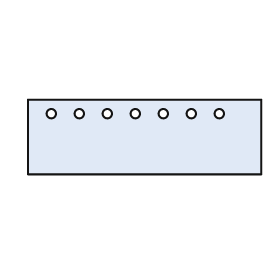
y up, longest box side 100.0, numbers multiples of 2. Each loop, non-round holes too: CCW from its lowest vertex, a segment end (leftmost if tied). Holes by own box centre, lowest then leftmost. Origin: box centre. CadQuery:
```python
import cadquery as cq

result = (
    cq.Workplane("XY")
    .moveTo(-50.0, -16.0)
    .lineTo(50.0, -16.0)
    .lineTo(50.0, 16.0)
    .lineTo(-50.0, 16.0)
    .close()
    .moveTo(-40.0, 10.0)
    .circle(2.0)
    .moveTo(-28.0, 10.0)
    .circle(2.0)
    .moveTo(-16.0, 10.0)
    .circle(2.0)
    .moveTo(-4.0, 10.0)
    .circle(2.0)
    .moveTo(8.0, 10.0)
    .circle(2.0)
    .moveTo(20.0, 10.0)
    .circle(2.0)
    .moveTo(32.0, 10.0)
    .circle(2.0)
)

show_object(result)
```